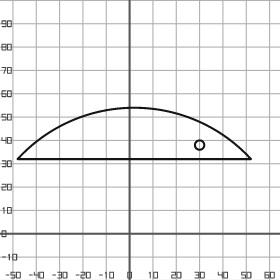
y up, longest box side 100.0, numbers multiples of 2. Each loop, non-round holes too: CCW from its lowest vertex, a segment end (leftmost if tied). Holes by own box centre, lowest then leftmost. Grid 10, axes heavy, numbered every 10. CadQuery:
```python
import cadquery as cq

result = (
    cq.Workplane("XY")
    .moveTo(-48.0, 32.0)
    .lineTo(52.0, 32.0)
    .threePointArc((2.0, 54.0), (-48.0, 32.0))
    .close()
    .moveTo(30.0, 38.0)
    .circle(2.0)
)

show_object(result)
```